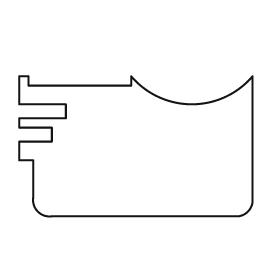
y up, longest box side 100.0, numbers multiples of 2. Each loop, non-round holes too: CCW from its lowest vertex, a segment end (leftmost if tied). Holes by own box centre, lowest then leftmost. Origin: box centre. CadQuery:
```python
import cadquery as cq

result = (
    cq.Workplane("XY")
    .moveTo(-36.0, -30.0)
    .lineTo(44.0, -30.0)
    .threePointArc((48.0, -28.0), (50.0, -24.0))
    .lineTo(50.0, 30.0)
    .threePointArc((24.0, 18.0), (-2.0, 30.0))
    .lineTo(-2.0, 26.0)
    .lineTo(-46.0, 26.0)
    .lineTo(-46.0, 30.0)
    .lineTo(-50.0, 30.0)
    .lineTo(-50.0, 18.0)
    .lineTo(-30.0, 18.0)
    .lineTo(-30.0, 12.0)
    .lineTo(-50.0, 12.0)
    .lineTo(-50.0, 8.0)
    .lineTo(-36.0, 8.0)
    .lineTo(-36.0, 2.0)
    .lineTo(-50.0, 2.0)
    .lineTo(-50.0, -6.0)
    .lineTo(-44.0, -6.0)
    .lineTo(-44.0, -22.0)
    .threePointArc((-42.0, -28.0), (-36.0, -30.0))
    .close()
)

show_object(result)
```